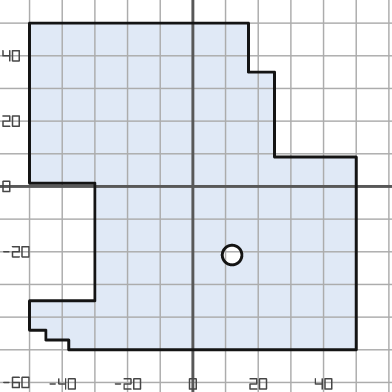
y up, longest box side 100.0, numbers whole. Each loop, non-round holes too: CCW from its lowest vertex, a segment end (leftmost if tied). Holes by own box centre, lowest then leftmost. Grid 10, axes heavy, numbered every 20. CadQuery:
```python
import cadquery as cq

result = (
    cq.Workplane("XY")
    .moveTo(-38.0, -50.0)
    .lineTo(50.0, -50.0)
    .lineTo(50.0, 9.0)
    .lineTo(25.0, 9.0)
    .lineTo(25.0, 35.0)
    .lineTo(17.0, 35.0)
    .lineTo(17.0, 50.0)
    .lineTo(-50.0, 50.0)
    .lineTo(-50.0, 1.0)
    .lineTo(-30.0, 1.0)
    .lineTo(-30.0, -35.0)
    .lineTo(-50.0, -35.0)
    .lineTo(-50.0, -44.0)
    .lineTo(-45.0, -44.0)
    .lineTo(-45.0, -47.0)
    .lineTo(-38.0, -47.0)
    .close()
    .moveTo(12.0, -21.0)
    .circle(3.0)
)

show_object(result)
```